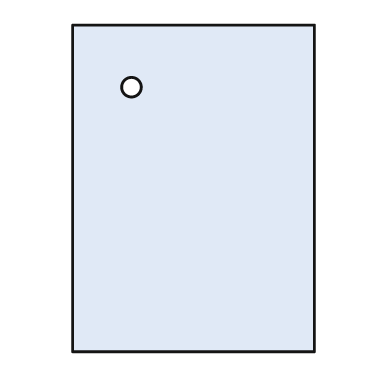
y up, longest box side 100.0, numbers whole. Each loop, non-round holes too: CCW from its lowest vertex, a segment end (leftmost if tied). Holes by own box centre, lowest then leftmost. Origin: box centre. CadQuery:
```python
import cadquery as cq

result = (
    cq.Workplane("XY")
    .moveTo(-37.0, -50.0)
    .lineTo(37.0, -50.0)
    .lineTo(37.0, 50.0)
    .lineTo(-37.0, 50.0)
    .close()
    .moveTo(-19.0, 31.0)
    .circle(3.0)
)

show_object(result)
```